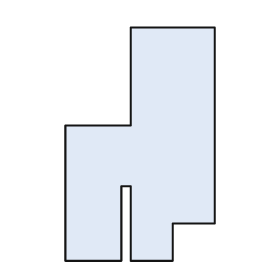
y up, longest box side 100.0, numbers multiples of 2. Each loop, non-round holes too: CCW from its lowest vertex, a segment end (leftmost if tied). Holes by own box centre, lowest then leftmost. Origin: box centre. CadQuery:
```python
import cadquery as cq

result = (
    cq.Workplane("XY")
    .moveTo(-32.0, -50.0)
    .lineTo(-8.0, -50.0)
    .lineTo(-8.0, -18.0)
    .lineTo(-4.0, -18.0)
    .lineTo(-4.0, -50.0)
    .lineTo(14.0, -50.0)
    .lineTo(14.0, -34.0)
    .lineTo(32.0, -34.0)
    .lineTo(32.0, 50.0)
    .lineTo(-4.0, 50.0)
    .lineTo(-4.0, 8.0)
    .lineTo(-32.0, 8.0)
    .close()
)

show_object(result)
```